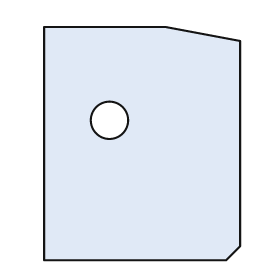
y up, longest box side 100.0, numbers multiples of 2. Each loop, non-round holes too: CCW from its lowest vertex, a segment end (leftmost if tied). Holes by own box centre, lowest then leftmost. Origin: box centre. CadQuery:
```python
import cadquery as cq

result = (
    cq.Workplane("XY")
    .moveTo(-42.0, -50.0)
    .lineTo(36.0, -50.0)
    .lineTo(42.0, -44.0)
    .lineTo(42.0, 44.0)
    .lineTo(10.0, 50.0)
    .lineTo(-42.0, 50.0)
    .close()
    .moveTo(-14.0, 10.0)
    .circle(8.0)
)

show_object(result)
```